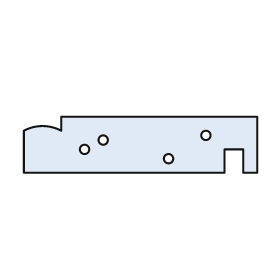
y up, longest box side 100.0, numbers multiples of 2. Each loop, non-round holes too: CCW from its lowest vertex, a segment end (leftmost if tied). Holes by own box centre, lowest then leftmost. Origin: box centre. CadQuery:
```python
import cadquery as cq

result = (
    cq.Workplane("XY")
    .moveTo(-50.0, -12.0)
    .lineTo(36.0, -12.0)
    .lineTo(36.0, -2.0)
    .lineTo(44.0, -2.0)
    .lineTo(44.0, -12.0)
    .lineTo(50.0, -12.0)
    .lineTo(50.0, 12.0)
    .lineTo(-34.0, 12.0)
    .lineTo(-34.0, 6.0)
    .threePointArc((-42.0, 8.0), (-50.0, 6.0))
    .close()
    .moveTo(12.0, -6.0)
    .circle(2.0)
    .moveTo(-24.0, -2.0)
    .circle(2.0)
    .moveTo(-16.0, 2.0)
    .circle(2.0)
    .moveTo(28.0, 4.0)
    .circle(2.0)
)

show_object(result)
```